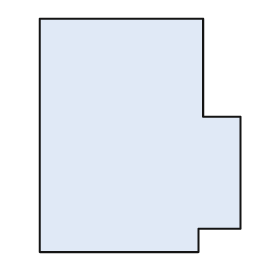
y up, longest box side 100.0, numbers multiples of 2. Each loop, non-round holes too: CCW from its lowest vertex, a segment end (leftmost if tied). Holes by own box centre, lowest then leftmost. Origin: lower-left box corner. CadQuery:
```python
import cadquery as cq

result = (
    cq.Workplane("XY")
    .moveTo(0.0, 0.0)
    .lineTo(68.0, 0.0)
    .lineTo(68.0, 10.0)
    .lineTo(86.0, 10.0)
    .lineTo(86.0, 58.0)
    .lineTo(70.0, 58.0)
    .lineTo(70.0, 100.0)
    .lineTo(0.0, 100.0)
    .close()
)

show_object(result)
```